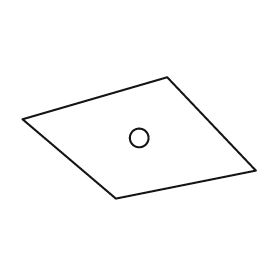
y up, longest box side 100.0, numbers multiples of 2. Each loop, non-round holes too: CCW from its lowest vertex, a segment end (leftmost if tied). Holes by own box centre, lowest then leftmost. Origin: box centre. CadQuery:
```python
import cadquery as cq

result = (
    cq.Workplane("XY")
    .moveTo(-10.0, -26.0)
    .lineTo(50.0, -14.0)
    .lineTo(12.0, 26.0)
    .lineTo(-50.0, 8.0)
    .close()
    .moveTo(0.0, 0.0)
    .circle(4.0)
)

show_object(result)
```